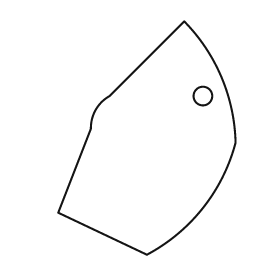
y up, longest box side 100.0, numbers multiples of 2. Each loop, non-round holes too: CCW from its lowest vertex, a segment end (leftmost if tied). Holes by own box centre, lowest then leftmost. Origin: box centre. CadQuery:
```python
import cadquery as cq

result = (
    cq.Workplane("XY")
    .moveTo(0.0, -50.0)
    .threePointArc((24.0, -30.0), (38.0, -2.0))
    .threePointArc((32.0, 26.0), (16.0, 50.0))
    .lineTo(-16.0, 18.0)
    .threePointArc((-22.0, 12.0), (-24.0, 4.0))
    .lineTo(-38.0, -32.0)
    .close()
    .moveTo(24.0, 18.0)
    .circle(4.0)
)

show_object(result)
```